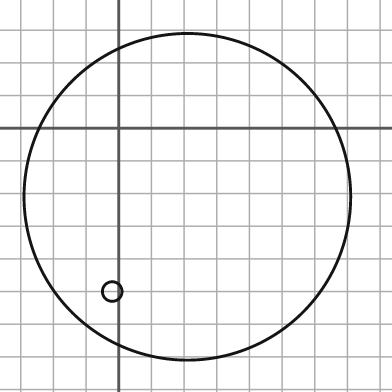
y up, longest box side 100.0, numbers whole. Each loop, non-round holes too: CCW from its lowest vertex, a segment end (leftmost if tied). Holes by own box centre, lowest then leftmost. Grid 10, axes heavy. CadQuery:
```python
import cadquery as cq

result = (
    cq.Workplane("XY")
    .moveTo(21.0, -21.0)
    .circle(50.0)
    .moveTo(-2.0, -50.0)
    .circle(3.0)
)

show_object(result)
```